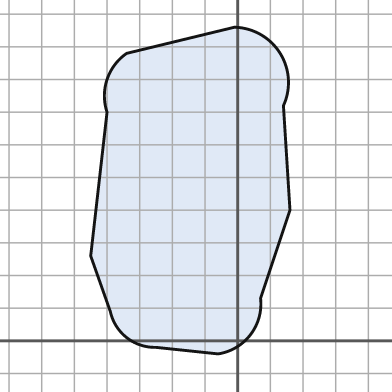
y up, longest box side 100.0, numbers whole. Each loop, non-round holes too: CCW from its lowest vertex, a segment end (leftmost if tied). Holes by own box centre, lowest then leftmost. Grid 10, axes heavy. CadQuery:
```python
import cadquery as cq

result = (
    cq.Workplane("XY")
    .moveTo(-6.0, -4.0)
    .threePointArc((4.0, 2.0), (7.0, 13.0))
    .lineTo(16.0, 40.0)
    .lineTo(14.0, 72.0)
    .threePointArc((13.0, 88.0), (-1.0, 96.0))
    .lineTo(-34.0, 88.0)
    .threePointArc((-40.0, 80.0), (-40.0, 70.0))
    .lineTo(-45.0, 26.0)
    .lineTo(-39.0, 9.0)
    .threePointArc((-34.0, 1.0), (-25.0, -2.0))
    .close()
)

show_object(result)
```